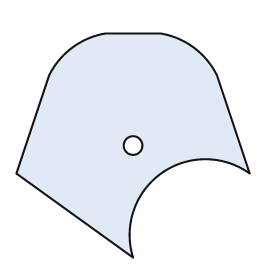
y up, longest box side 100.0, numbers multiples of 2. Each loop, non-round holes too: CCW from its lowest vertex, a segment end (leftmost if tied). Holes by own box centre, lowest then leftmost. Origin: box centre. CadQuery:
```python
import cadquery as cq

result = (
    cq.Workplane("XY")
    .moveTo(0.0, -48.0)
    .threePointArc((12.0, -12.0), (50.0, -12.0))
    .lineTo(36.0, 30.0)
    .threePointArc((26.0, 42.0), (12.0, 48.0))
    .lineTo(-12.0, 48.0)
    .threePointArc((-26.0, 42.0), (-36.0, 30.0))
    .lineTo(-50.0, -12.0)
    .close()
    .moveTo(0.0, 0.0)
    .circle(4.0)
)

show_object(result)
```